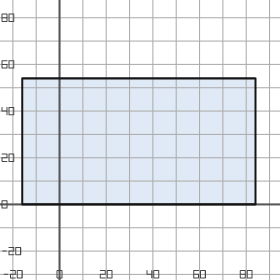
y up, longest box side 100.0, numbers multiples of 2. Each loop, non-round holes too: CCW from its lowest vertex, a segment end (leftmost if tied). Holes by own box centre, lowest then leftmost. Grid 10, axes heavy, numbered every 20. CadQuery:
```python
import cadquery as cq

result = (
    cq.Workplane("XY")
    .moveTo(-16.0, 0.0)
    .lineTo(84.0, 0.0)
    .lineTo(84.0, 54.0)
    .lineTo(-16.0, 54.0)
    .close()
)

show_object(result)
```